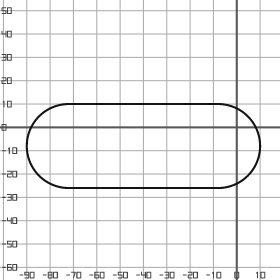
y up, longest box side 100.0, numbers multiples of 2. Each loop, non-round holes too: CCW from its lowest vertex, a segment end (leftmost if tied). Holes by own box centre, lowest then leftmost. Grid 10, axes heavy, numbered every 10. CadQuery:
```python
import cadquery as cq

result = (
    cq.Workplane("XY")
    .moveTo(-72.0, -26.0)
    .lineTo(-8.0, -26.0)
    .threePointArc((10.0, -8.0), (-8.0, 10.0))
    .lineTo(-72.0, 10.0)
    .threePointArc((-90.0, -8.0), (-72.0, -26.0))
    .close()
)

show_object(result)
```